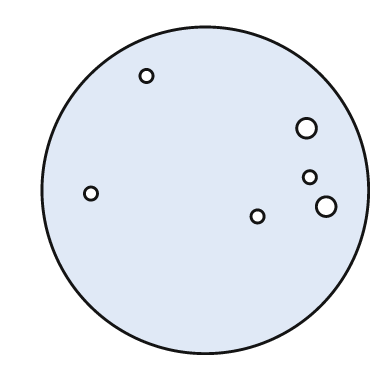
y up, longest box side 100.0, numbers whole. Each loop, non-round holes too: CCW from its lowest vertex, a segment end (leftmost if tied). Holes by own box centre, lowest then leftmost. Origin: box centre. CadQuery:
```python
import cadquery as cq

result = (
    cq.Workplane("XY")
    .moveTo(0.0, 0.0)
    .circle(50.0)
    .moveTo(16.0, -8.0)
    .circle(2.0)
    .moveTo(37.0, -5.0)
    .circle(3.0)
    .moveTo(-35.0, -1.0)
    .circle(2.0)
    .moveTo(32.0, 4.0)
    .circle(2.0)
    .moveTo(31.0, 19.0)
    .circle(3.0)
    .moveTo(-18.0, 35.0)
    .circle(2.0)
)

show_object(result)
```